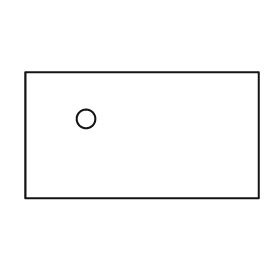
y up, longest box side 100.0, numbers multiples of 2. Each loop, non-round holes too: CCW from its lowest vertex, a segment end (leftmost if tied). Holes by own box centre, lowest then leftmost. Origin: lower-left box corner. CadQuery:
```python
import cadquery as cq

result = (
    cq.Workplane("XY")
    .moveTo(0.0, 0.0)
    .lineTo(100.0, 0.0)
    .lineTo(100.0, 54.0)
    .lineTo(0.0, 54.0)
    .close()
    .moveTo(26.0, 34.0)
    .circle(4.0)
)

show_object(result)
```